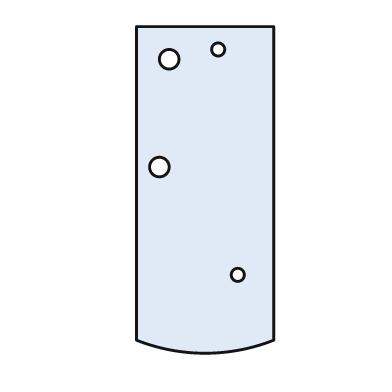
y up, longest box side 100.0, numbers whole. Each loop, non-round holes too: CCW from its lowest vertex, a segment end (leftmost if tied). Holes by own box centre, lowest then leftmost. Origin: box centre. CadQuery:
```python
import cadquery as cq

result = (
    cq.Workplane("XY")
    .moveTo(-21.0, -46.0)
    .threePointArc((0.0, -50.0), (21.0, -46.0))
    .lineTo(21.0, 50.0)
    .lineTo(-21.0, 50.0)
    .close()
    .moveTo(10.0, -26.0)
    .circle(2.0)
    .moveTo(-14.0, 7.0)
    .circle(3.0)
    .moveTo(-11.0, 40.0)
    .circle(3.0)
    .moveTo(4.0, 43.0)
    .circle(2.0)
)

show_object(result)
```